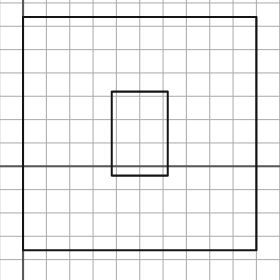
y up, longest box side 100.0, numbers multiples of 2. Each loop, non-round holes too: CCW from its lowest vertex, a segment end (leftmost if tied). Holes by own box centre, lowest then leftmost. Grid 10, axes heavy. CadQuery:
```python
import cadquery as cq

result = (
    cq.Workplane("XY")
    .moveTo(0.0, -36.0)
    .lineTo(100.0, -36.0)
    .lineTo(100.0, 64.0)
    .lineTo(0.0, 64.0)
    .close()
    .moveTo(38.0, -4.0)
    .lineTo(62.0, -4.0)
    .lineTo(62.0, 32.0)
    .lineTo(38.0, 32.0)
    .close()
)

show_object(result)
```